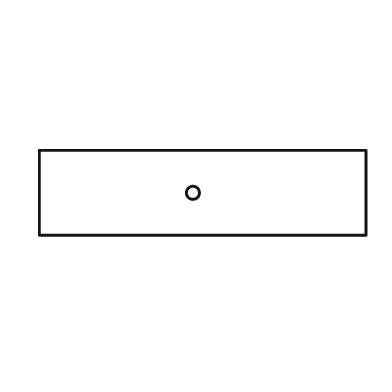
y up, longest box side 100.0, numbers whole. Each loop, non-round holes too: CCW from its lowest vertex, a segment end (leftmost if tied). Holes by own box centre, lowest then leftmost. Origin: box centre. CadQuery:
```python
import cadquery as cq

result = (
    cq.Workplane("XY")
    .moveTo(-50.0, -13.0)
    .lineTo(50.0, -13.0)
    .lineTo(50.0, 13.0)
    .lineTo(-50.0, 13.0)
    .close()
    .moveTo(-3.0, 0.0)
    .circle(2.0)
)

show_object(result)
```